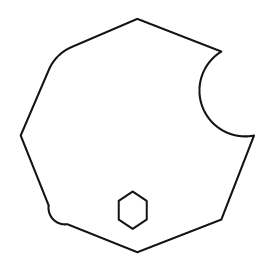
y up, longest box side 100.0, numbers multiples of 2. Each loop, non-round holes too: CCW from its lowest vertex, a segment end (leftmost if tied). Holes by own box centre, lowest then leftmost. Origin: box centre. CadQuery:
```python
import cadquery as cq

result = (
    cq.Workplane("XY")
    .moveTo(0.0, -50.0)
    .lineTo(36.0, -36.0)
    .lineTo(50.0, 0.0)
    .threePointArc((28.0, 12.0), (36.0, 36.0))
    .lineTo(0.0, 50.0)
    .lineTo(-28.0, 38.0)
    .threePointArc((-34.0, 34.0), (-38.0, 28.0))
    .lineTo(-50.0, 0.0)
    .lineTo(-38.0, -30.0)
    .threePointArc((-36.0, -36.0), (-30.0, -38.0))
    .close()
    .moveTo(-2.0, -40.0)
    .lineTo(4.0, -36.0)
    .lineTo(4.0, -28.0)
    .lineTo(-2.0, -24.0)
    .lineTo(-8.0, -28.0)
    .lineTo(-8.0, -36.0)
    .close()
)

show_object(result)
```